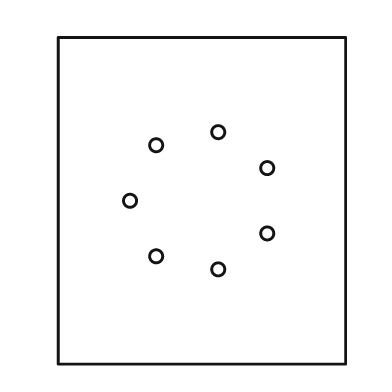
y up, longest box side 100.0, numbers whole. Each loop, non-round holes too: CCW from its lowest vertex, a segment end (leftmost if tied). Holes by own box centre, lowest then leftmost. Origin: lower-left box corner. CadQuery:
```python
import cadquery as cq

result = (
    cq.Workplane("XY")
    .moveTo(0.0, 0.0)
    .lineTo(88.0, 0.0)
    .lineTo(88.0, 100.0)
    .lineTo(0.0, 100.0)
    .close()
    .moveTo(49.0, 29.0)
    .circle(2.0)
    .moveTo(30.0, 33.0)
    .circle(2.0)
    .moveTo(64.0, 40.0)
    .circle(2.0)
    .moveTo(22.0, 50.0)
    .circle(2.0)
    .moveTo(64.0, 60.0)
    .circle(2.0)
    .moveTo(30.0, 67.0)
    .circle(2.0)
    .moveTo(49.0, 71.0)
    .circle(2.0)
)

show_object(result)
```